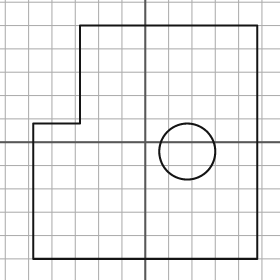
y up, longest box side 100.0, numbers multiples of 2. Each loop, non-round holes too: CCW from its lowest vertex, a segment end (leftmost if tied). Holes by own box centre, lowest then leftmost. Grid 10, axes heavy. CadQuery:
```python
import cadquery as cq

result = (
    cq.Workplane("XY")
    .moveTo(-48.0, -50.0)
    .lineTo(48.0, -50.0)
    .lineTo(48.0, 50.0)
    .lineTo(-28.0, 50.0)
    .lineTo(-28.0, 8.0)
    .lineTo(-48.0, 8.0)
    .close()
    .moveTo(18.0, -4.0)
    .circle(12.0)
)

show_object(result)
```